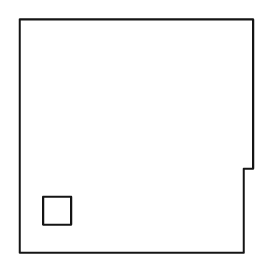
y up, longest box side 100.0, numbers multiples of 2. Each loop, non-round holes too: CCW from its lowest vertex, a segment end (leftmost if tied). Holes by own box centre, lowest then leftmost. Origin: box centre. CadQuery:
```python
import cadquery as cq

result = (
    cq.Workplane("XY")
    .moveTo(-50.0, -50.0)
    .lineTo(46.0, -50.0)
    .lineTo(46.0, -14.0)
    .lineTo(50.0, -14.0)
    .lineTo(50.0, 50.0)
    .lineTo(-50.0, 50.0)
    .close()
    .moveTo(-40.0, -38.0)
    .lineTo(-28.0, -38.0)
    .lineTo(-28.0, -26.0)
    .lineTo(-40.0, -26.0)
    .close()
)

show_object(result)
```